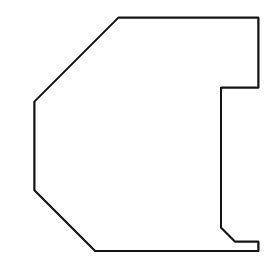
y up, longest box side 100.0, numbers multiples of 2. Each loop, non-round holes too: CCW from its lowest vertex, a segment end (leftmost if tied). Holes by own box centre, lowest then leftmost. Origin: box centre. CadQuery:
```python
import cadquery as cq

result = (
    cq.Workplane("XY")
    .moveTo(-22.0, -50.0)
    .lineTo(48.0, -50.0)
    .lineTo(48.0, -46.0)
    .lineTo(38.0, -46.0)
    .lineTo(32.0, -40.0)
    .lineTo(32.0, 20.0)
    .lineTo(48.0, 20.0)
    .lineTo(48.0, 50.0)
    .lineTo(-12.0, 50.0)
    .lineTo(-48.0, 14.0)
    .lineTo(-48.0, -24.0)
    .close()
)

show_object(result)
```